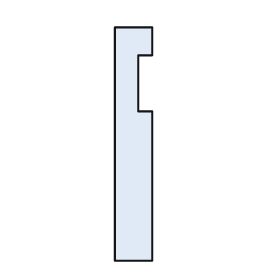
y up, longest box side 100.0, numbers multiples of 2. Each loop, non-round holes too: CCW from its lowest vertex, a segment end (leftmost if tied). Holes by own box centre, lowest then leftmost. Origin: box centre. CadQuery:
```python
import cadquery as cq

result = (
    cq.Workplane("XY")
    .moveTo(-8.0, -50.0)
    .lineTo(8.0, -50.0)
    .lineTo(8.0, 14.0)
    .lineTo(2.0, 14.0)
    .lineTo(2.0, 38.0)
    .lineTo(8.0, 38.0)
    .lineTo(8.0, 50.0)
    .lineTo(-8.0, 50.0)
    .close()
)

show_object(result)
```